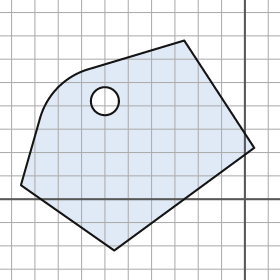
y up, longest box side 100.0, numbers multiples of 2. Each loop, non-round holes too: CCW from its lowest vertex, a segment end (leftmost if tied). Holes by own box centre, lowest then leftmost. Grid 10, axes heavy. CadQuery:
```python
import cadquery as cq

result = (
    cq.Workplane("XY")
    .moveTo(-56.0, -22.0)
    .lineTo(4.0, 22.0)
    .lineTo(-26.0, 68.0)
    .lineTo(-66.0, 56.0)
    .threePointArc((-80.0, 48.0), (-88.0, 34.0))
    .lineTo(-96.0, 6.0)
    .close()
    .moveTo(-60.0, 42.0)
    .circle(6.0)
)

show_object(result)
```